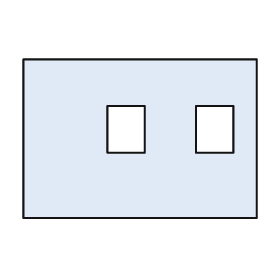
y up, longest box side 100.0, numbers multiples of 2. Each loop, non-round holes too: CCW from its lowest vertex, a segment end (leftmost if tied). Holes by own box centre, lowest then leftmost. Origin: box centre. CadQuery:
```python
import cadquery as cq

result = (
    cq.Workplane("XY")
    .moveTo(-50.0, -34.0)
    .lineTo(50.0, -34.0)
    .lineTo(50.0, 34.0)
    .lineTo(-50.0, 34.0)
    .close()
    .moveTo(-14.0, -6.0)
    .lineTo(2.0, -6.0)
    .lineTo(2.0, 14.0)
    .lineTo(-14.0, 14.0)
    .close()
    .moveTo(24.0, -6.0)
    .lineTo(40.0, -6.0)
    .lineTo(40.0, 14.0)
    .lineTo(24.0, 14.0)
    .close()
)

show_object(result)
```